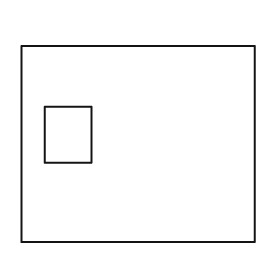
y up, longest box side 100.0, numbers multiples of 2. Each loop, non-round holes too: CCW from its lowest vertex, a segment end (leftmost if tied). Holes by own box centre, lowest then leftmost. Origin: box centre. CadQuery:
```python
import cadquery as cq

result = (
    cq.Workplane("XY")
    .moveTo(-50.0, -42.0)
    .lineTo(50.0, -42.0)
    .lineTo(50.0, 42.0)
    .lineTo(-50.0, 42.0)
    .close()
    .moveTo(-40.0, -8.0)
    .lineTo(-20.0, -8.0)
    .lineTo(-20.0, 16.0)
    .lineTo(-40.0, 16.0)
    .close()
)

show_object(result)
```